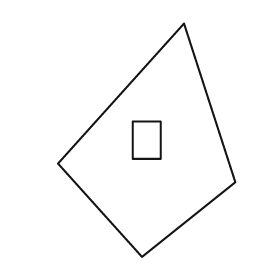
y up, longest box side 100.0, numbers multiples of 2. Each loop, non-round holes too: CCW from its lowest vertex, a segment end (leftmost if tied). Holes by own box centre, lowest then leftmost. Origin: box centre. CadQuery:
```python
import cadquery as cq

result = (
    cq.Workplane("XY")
    .moveTo(-2.0, -50.0)
    .lineTo(38.0, -18.0)
    .lineTo(16.0, 50.0)
    .lineTo(-38.0, -10.0)
    .close()
    .moveTo(-6.0, -8.0)
    .lineTo(6.0, -8.0)
    .lineTo(6.0, 8.0)
    .lineTo(-6.0, 8.0)
    .close()
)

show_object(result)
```